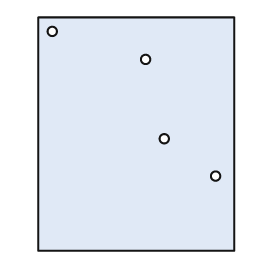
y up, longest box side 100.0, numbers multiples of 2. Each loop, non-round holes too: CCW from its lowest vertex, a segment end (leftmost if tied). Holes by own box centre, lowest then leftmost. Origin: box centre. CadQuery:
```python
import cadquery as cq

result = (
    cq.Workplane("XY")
    .moveTo(-42.0, -50.0)
    .lineTo(42.0, -50.0)
    .lineTo(42.0, 50.0)
    .lineTo(-42.0, 50.0)
    .close()
    .moveTo(34.0, -18.0)
    .circle(2.0)
    .moveTo(12.0, -2.0)
    .circle(2.0)
    .moveTo(4.0, 32.0)
    .circle(2.0)
    .moveTo(-36.0, 44.0)
    .circle(2.0)
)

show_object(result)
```